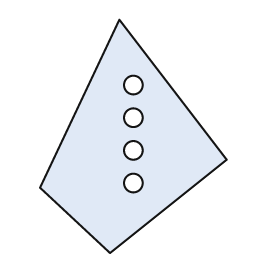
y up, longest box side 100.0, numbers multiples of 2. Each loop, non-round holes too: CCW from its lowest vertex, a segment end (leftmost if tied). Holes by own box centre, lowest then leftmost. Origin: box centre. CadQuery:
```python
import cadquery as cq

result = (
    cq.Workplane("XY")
    .moveTo(-10.0, -50.0)
    .lineTo(40.0, -10.0)
    .lineTo(-6.0, 50.0)
    .lineTo(-40.0, -22.0)
    .close()
    .moveTo(0.0, -20.0)
    .circle(4.0)
    .moveTo(0.0, -6.0)
    .circle(4.0)
    .moveTo(0.0, 8.0)
    .circle(4.0)
    .moveTo(0.0, 22.0)
    .circle(4.0)
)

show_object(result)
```